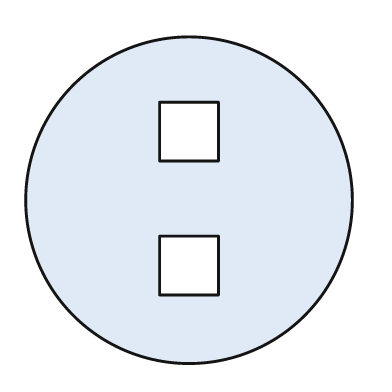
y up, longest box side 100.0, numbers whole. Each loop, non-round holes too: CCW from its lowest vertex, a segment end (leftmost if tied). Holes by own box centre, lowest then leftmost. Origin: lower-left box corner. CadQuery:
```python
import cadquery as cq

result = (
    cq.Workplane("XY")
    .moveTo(50.0, 50.0)
    .circle(50.0)
    .moveTo(41.0, 21.0)
    .lineTo(59.0, 21.0)
    .lineTo(59.0, 39.0)
    .lineTo(41.0, 39.0)
    .close()
    .moveTo(41.0, 62.0)
    .lineTo(59.0, 62.0)
    .lineTo(59.0, 80.0)
    .lineTo(41.0, 80.0)
    .close()
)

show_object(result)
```